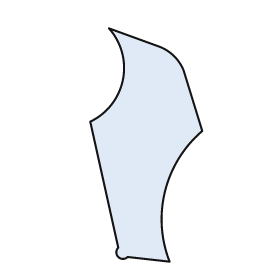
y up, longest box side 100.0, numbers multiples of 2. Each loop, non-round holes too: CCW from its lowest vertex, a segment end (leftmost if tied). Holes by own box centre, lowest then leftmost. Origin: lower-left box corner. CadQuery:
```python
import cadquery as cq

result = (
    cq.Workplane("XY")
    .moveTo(34.0, 0.0)
    .threePointArc((32.0, 30.0), (48.0, 56.0))
    .lineTo(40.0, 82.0)
    .threePointArc((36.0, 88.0), (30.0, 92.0))
    .lineTo(8.0, 100.0)
    .threePointArc((14.0, 78.0), (0.0, 60.0))
    .lineTo(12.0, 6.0)
    .threePointArc((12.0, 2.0), (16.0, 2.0))
    .close()
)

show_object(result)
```